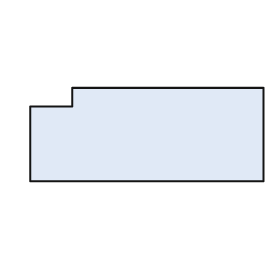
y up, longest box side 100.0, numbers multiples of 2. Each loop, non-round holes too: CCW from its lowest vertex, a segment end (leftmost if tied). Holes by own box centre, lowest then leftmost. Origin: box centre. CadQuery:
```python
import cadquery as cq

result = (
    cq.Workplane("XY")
    .moveTo(-50.0, -20.0)
    .lineTo(50.0, -20.0)
    .lineTo(50.0, 20.0)
    .lineTo(-32.0, 20.0)
    .lineTo(-32.0, 12.0)
    .lineTo(-50.0, 12.0)
    .close()
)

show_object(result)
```